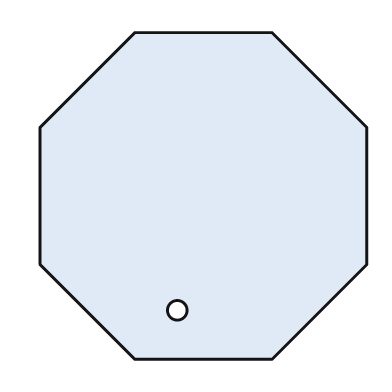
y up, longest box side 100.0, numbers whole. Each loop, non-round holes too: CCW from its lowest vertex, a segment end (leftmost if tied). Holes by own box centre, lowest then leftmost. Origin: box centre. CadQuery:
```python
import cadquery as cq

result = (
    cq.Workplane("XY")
    .moveTo(-21.0, -50.0)
    .lineTo(21.0, -50.0)
    .lineTo(50.0, -21.0)
    .lineTo(50.0, 21.0)
    .lineTo(21.0, 50.0)
    .lineTo(-21.0, 50.0)
    .lineTo(-50.0, 21.0)
    .lineTo(-50.0, -21.0)
    .close()
    .moveTo(-8.0, -35.0)
    .circle(3.0)
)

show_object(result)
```